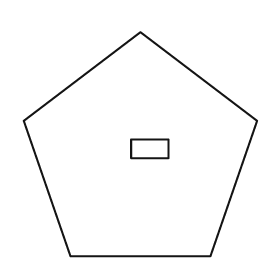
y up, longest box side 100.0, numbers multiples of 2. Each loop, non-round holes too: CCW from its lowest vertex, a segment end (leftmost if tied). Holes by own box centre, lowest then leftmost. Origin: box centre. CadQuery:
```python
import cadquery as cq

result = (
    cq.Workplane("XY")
    .moveTo(-30.0, -48.0)
    .lineTo(30.0, -48.0)
    .lineTo(50.0, 10.0)
    .lineTo(0.0, 48.0)
    .lineTo(-50.0, 10.0)
    .close()
    .moveTo(-4.0, -6.0)
    .lineTo(12.0, -6.0)
    .lineTo(12.0, 2.0)
    .lineTo(-4.0, 2.0)
    .close()
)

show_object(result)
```